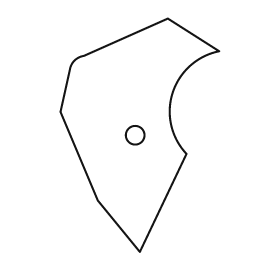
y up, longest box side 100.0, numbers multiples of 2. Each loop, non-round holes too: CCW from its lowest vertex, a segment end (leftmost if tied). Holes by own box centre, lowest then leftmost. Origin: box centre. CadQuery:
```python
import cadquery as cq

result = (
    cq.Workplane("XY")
    .moveTo(0.0, -50.0)
    .lineTo(20.0, -8.0)
    .threePointArc((14.0, 18.0), (34.0, 36.0))
    .lineTo(12.0, 50.0)
    .lineTo(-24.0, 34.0)
    .threePointArc((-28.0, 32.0), (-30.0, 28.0))
    .lineTo(-34.0, 10.0)
    .lineTo(-18.0, -28.0)
    .close()
    .moveTo(-2.0, 0.0)
    .circle(4.0)
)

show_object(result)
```